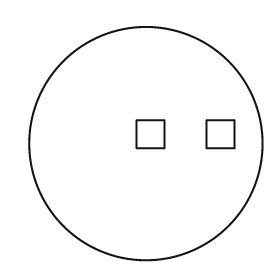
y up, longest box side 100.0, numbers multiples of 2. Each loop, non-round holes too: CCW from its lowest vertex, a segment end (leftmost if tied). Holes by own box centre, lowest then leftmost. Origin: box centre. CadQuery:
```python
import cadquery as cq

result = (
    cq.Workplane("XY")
    .moveTo(0.0, 0.0)
    .circle(50.0)
    .moveTo(-4.0, -2.0)
    .lineTo(8.0, -2.0)
    .lineTo(8.0, 10.0)
    .lineTo(-4.0, 10.0)
    .close()
    .moveTo(26.0, -2.0)
    .lineTo(38.0, -2.0)
    .lineTo(38.0, 10.0)
    .lineTo(26.0, 10.0)
    .close()
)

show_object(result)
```